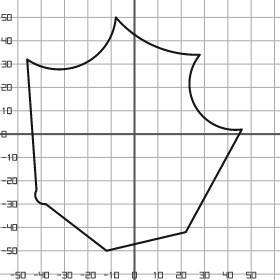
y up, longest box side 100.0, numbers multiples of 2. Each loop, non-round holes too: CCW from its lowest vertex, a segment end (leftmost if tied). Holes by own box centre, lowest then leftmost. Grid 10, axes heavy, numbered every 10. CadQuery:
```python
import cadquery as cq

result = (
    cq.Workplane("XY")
    .moveTo(-12.0, -50.0)
    .lineTo(22.0, -42.0)
    .lineTo(46.0, 2.0)
    .threePointArc((26.0, 12.0), (28.0, 34.0))
    .threePointArc((8.0, 38.0), (-8.0, 50.0))
    .threePointArc((-22.0, 30.0), (-46.0, 32.0))
    .lineTo(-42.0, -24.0)
    .threePointArc((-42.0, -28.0), (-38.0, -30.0))
    .close()
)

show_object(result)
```